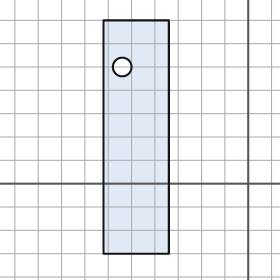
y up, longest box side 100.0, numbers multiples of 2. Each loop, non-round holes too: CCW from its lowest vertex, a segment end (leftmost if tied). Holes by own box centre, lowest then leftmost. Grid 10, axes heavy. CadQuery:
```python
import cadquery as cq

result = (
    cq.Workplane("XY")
    .moveTo(-62.0, -30.0)
    .lineTo(-34.0, -30.0)
    .lineTo(-34.0, 70.0)
    .lineTo(-62.0, 70.0)
    .close()
    .moveTo(-54.0, 50.0)
    .circle(4.0)
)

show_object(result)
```